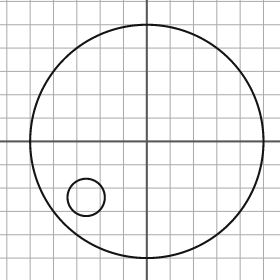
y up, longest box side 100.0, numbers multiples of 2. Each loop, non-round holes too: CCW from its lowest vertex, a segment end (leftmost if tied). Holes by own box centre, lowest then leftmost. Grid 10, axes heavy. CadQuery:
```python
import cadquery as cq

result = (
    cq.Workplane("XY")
    .moveTo(0.0, 0.0)
    .circle(50.0)
    .moveTo(-26.0, -24.0)
    .circle(8.0)
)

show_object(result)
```